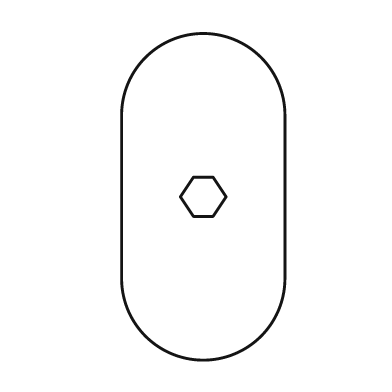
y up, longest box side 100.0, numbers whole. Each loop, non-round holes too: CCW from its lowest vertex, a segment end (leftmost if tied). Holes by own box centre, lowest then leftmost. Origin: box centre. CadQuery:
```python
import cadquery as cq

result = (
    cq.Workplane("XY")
    .moveTo(-25.0, -25.0)
    .threePointArc((0.0, -50.0), (25.0, -25.0))
    .lineTo(25.0, 25.0)
    .threePointArc((0.0, 50.0), (-25.0, 25.0))
    .close()
    .moveTo(-3.0, -6.0)
    .lineTo(3.0, -6.0)
    .lineTo(7.0, 0.0)
    .lineTo(3.0, 6.0)
    .lineTo(-3.0, 6.0)
    .lineTo(-7.0, 0.0)
    .close()
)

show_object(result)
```